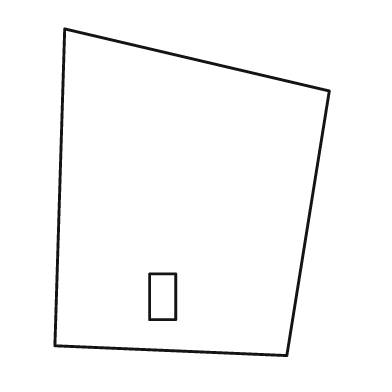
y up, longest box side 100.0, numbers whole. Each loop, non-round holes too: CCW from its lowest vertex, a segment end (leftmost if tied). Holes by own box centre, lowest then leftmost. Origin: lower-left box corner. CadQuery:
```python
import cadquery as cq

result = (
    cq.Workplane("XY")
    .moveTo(71.0, 0.0)
    .lineTo(84.0, 81.0)
    .lineTo(3.0, 100.0)
    .lineTo(0.0, 3.0)
    .close()
    .moveTo(29.0, 11.0)
    .lineTo(37.0, 11.0)
    .lineTo(37.0, 25.0)
    .lineTo(29.0, 25.0)
    .close()
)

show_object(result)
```